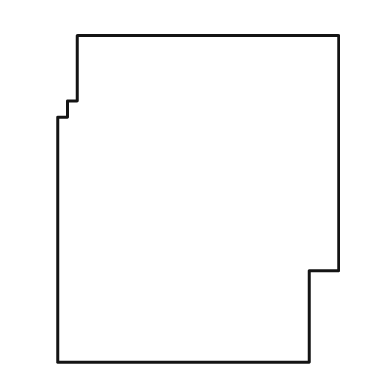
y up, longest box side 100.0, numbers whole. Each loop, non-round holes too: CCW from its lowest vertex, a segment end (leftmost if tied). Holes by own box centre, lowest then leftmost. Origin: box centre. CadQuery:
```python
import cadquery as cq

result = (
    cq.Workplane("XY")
    .moveTo(-43.0, -50.0)
    .lineTo(34.0, -50.0)
    .lineTo(34.0, -22.0)
    .lineTo(43.0, -22.0)
    .lineTo(43.0, 50.0)
    .lineTo(-37.0, 50.0)
    .lineTo(-37.0, 30.0)
    .lineTo(-40.0, 30.0)
    .lineTo(-40.0, 25.0)
    .lineTo(-43.0, 25.0)
    .close()
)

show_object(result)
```